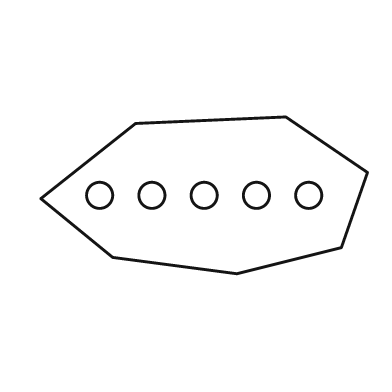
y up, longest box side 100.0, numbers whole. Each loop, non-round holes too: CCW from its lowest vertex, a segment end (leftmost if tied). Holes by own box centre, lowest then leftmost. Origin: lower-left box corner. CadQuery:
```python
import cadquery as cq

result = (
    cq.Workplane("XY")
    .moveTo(60.0, 0.0)
    .lineTo(92.0, 8.0)
    .lineTo(100.0, 31.0)
    .lineTo(75.0, 48.0)
    .lineTo(29.0, 46.0)
    .lineTo(0.0, 23.0)
    .lineTo(22.0, 5.0)
    .close()
    .moveTo(18.0, 24.0)
    .circle(4.0)
    .moveTo(34.0, 24.0)
    .circle(4.0)
    .moveTo(50.0, 24.0)
    .circle(4.0)
    .moveTo(66.0, 24.0)
    .circle(4.0)
    .moveTo(82.0, 24.0)
    .circle(4.0)
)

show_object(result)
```